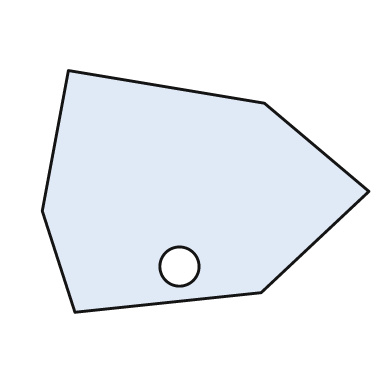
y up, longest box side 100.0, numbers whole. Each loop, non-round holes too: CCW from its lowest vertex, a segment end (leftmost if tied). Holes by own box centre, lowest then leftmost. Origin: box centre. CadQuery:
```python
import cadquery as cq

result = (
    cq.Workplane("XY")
    .moveTo(-40.0, -37.0)
    .lineTo(17.0, -31.0)
    .lineTo(50.0, 0.0)
    .lineTo(18.0, 27.0)
    .lineTo(-42.0, 37.0)
    .lineTo(-50.0, -6.0)
    .close()
    .moveTo(-8.0, -23.0)
    .circle(6.0)
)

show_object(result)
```